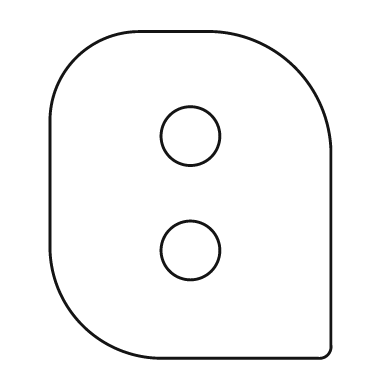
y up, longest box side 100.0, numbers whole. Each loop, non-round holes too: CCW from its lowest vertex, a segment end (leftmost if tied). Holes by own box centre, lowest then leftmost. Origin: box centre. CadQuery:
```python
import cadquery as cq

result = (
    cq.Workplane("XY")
    .moveTo(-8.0, -50.0)
    .lineTo(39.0, -50.0)
    .threePointArc((42.0, -49.0), (43.0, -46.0))
    .lineTo(43.0, 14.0)
    .threePointArc((32.0, 39.0), (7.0, 50.0))
    .lineTo(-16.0, 50.0)
    .threePointArc((-35.0, 42.0), (-43.0, 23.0))
    .lineTo(-43.0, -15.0)
    .threePointArc((-33.0, -40.0), (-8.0, -50.0))
    .close()
    .moveTo(0.0, -17.0)
    .circle(9.0)
    .moveTo(0.0, 18.0)
    .circle(9.0)
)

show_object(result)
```